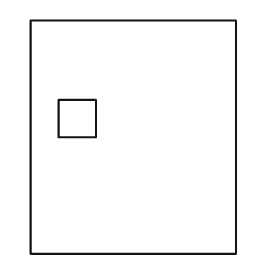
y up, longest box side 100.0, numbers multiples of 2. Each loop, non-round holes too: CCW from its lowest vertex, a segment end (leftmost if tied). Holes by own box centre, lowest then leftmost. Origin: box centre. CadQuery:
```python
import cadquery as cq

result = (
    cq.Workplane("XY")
    .moveTo(-44.0, -50.0)
    .lineTo(44.0, -50.0)
    .lineTo(44.0, 50.0)
    .lineTo(-44.0, 50.0)
    .close()
    .moveTo(-32.0, 0.0)
    .lineTo(-16.0, 0.0)
    .lineTo(-16.0, 16.0)
    .lineTo(-32.0, 16.0)
    .close()
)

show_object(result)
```